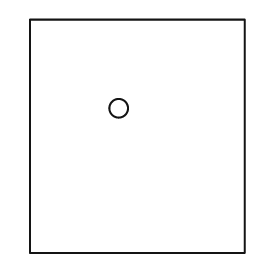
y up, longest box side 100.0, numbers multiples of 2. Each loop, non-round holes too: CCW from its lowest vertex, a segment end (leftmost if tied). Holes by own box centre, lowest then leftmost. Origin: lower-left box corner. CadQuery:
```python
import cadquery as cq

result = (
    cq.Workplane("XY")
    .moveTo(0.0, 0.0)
    .lineTo(92.0, 0.0)
    .lineTo(92.0, 100.0)
    .lineTo(0.0, 100.0)
    .close()
    .moveTo(38.0, 62.0)
    .circle(4.0)
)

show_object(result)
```